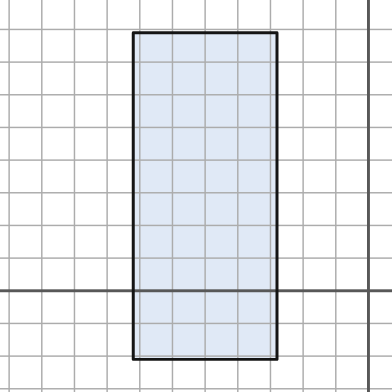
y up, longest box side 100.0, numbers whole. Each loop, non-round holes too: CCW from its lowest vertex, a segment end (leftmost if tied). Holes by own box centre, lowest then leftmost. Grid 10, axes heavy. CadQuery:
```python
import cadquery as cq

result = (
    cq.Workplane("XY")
    .moveTo(-72.0, -21.0)
    .lineTo(-28.0, -21.0)
    .lineTo(-28.0, 79.0)
    .lineTo(-72.0, 79.0)
    .close()
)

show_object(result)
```